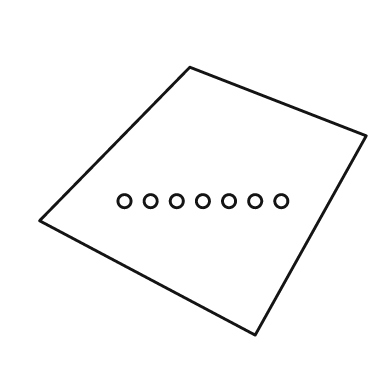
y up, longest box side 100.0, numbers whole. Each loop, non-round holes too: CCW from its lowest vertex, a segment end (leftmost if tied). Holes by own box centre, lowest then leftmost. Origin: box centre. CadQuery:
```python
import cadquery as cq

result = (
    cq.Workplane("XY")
    .moveTo(16.0, -41.0)
    .lineTo(50.0, 20.0)
    .lineTo(-4.0, 41.0)
    .lineTo(-50.0, -6.0)
    .close()
    .moveTo(-24.0, 0.0)
    .circle(2.0)
    .moveTo(-16.0, 0.0)
    .circle(2.0)
    .moveTo(-8.0, 0.0)
    .circle(2.0)
    .moveTo(0.0, 0.0)
    .circle(2.0)
    .moveTo(8.0, 0.0)
    .circle(2.0)
    .moveTo(16.0, 0.0)
    .circle(2.0)
    .moveTo(24.0, 0.0)
    .circle(2.0)
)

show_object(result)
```